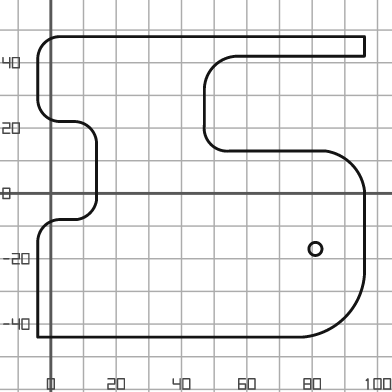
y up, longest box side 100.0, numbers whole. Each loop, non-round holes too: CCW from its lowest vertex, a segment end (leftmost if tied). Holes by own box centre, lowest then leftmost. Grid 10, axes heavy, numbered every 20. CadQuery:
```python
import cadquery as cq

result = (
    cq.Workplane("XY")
    .moveTo(-4.0, -44.0)
    .lineTo(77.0, -44.0)
    .threePointArc((90.0, -38.0), (96.0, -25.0))
    .lineTo(96.0, 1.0)
    .threePointArc((92.0, 9.0), (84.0, 13.0))
    .lineTo(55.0, 13.0)
    .threePointArc((49.0, 15.0), (47.0, 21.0))
    .lineTo(47.0, 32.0)
    .threePointArc((50.0, 39.0), (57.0, 42.0))
    .lineTo(96.0, 42.0)
    .lineTo(96.0, 48.0)
    .lineTo(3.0, 48.0)
    .threePointArc((-2.0, 46.0), (-4.0, 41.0))
    .lineTo(-4.0, 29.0)
    .threePointArc((-2.0, 24.0), (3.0, 22.0))
    .lineTo(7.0, 22.0)
    .threePointArc((12.0, 20.0), (14.0, 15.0))
    .lineTo(14.0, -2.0)
    .threePointArc((12.0, -6.0), (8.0, -8.0))
    .lineTo(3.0, -8.0)
    .threePointArc((-2.0, -10.0), (-4.0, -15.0))
    .close()
    .moveTo(81.0, -17.0)
    .circle(2.0)
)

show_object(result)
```